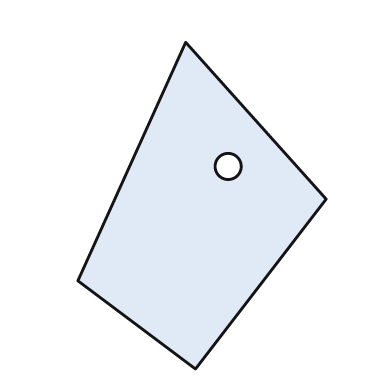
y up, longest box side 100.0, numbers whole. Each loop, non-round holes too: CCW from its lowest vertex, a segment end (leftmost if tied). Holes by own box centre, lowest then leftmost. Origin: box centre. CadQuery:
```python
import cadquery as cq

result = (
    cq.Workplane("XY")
    .moveTo(-2.0, -50.0)
    .lineTo(38.0, 2.0)
    .lineTo(-5.0, 50.0)
    .lineTo(-38.0, -23.0)
    .close()
    .moveTo(8.0, 12.0)
    .circle(4.0)
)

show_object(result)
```